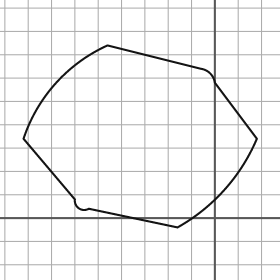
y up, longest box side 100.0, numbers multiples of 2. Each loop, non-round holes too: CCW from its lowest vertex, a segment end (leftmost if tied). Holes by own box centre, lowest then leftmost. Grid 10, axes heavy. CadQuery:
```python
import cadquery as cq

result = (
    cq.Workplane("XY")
    .moveTo(-16.0, -4.0)
    .threePointArc((4.0, 12.0), (18.0, 34.0))
    .lineTo(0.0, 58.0)
    .threePointArc((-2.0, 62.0), (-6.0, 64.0))
    .lineTo(-46.0, 74.0)
    .threePointArc((-68.0, 58.0), (-82.0, 34.0))
    .lineTo(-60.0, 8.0)
    .threePointArc((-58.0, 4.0), (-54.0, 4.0))
    .close()
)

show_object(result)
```